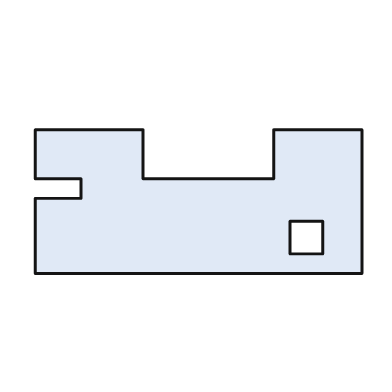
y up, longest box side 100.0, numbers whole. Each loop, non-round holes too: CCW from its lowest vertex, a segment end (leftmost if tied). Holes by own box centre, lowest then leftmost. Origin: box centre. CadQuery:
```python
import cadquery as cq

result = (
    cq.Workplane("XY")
    .moveTo(-50.0, -22.0)
    .lineTo(50.0, -22.0)
    .lineTo(50.0, 22.0)
    .lineTo(23.0, 22.0)
    .lineTo(23.0, 7.0)
    .lineTo(-17.0, 7.0)
    .lineTo(-17.0, 22.0)
    .lineTo(-50.0, 22.0)
    .lineTo(-50.0, 7.0)
    .lineTo(-36.0, 7.0)
    .lineTo(-36.0, 1.0)
    .lineTo(-50.0, 1.0)
    .close()
    .moveTo(28.0, -16.0)
    .lineTo(38.0, -16.0)
    .lineTo(38.0, -6.0)
    .lineTo(28.0, -6.0)
    .close()
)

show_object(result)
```